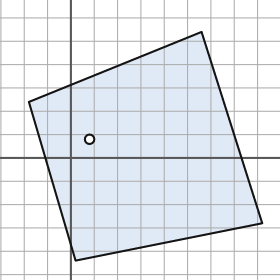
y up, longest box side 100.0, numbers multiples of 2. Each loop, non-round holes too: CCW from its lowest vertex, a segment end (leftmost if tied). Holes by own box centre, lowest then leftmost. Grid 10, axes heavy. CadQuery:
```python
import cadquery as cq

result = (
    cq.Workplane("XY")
    .moveTo(2.0, -44.0)
    .lineTo(82.0, -28.0)
    .lineTo(56.0, 54.0)
    .lineTo(-18.0, 24.0)
    .close()
    .moveTo(8.0, 8.0)
    .circle(2.0)
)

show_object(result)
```